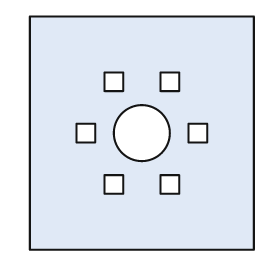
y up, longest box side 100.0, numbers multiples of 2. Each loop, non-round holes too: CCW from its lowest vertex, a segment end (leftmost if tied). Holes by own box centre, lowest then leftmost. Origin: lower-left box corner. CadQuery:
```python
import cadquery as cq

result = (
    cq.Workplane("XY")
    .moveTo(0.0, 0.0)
    .lineTo(96.0, 0.0)
    .lineTo(96.0, 100.0)
    .lineTo(0.0, 100.0)
    .close()
    .moveTo(32.0, 24.0)
    .lineTo(40.0, 24.0)
    .lineTo(40.0, 32.0)
    .lineTo(32.0, 32.0)
    .close()
    .moveTo(56.0, 24.0)
    .lineTo(64.0, 24.0)
    .lineTo(64.0, 32.0)
    .lineTo(56.0, 32.0)
    .close()
    .moveTo(20.0, 46.0)
    .lineTo(28.0, 46.0)
    .lineTo(28.0, 54.0)
    .lineTo(20.0, 54.0)
    .close()
    .moveTo(48.0, 50.0)
    .circle(12.0)
    .moveTo(68.0, 46.0)
    .lineTo(76.0, 46.0)
    .lineTo(76.0, 54.0)
    .lineTo(68.0, 54.0)
    .close()
    .moveTo(32.0, 68.0)
    .lineTo(40.0, 68.0)
    .lineTo(40.0, 76.0)
    .lineTo(32.0, 76.0)
    .close()
    .moveTo(56.0, 68.0)
    .lineTo(64.0, 68.0)
    .lineTo(64.0, 76.0)
    .lineTo(56.0, 76.0)
    .close()
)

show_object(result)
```